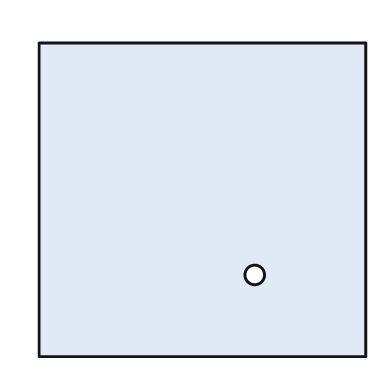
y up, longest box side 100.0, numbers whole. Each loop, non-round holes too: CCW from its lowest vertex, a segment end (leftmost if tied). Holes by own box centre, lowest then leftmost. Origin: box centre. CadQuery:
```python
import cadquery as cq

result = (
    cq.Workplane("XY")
    .moveTo(-50.0, -48.0)
    .lineTo(50.0, -48.0)
    .lineTo(50.0, 48.0)
    .lineTo(-50.0, 48.0)
    .close()
    .moveTo(16.0, -23.0)
    .circle(3.0)
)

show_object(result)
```